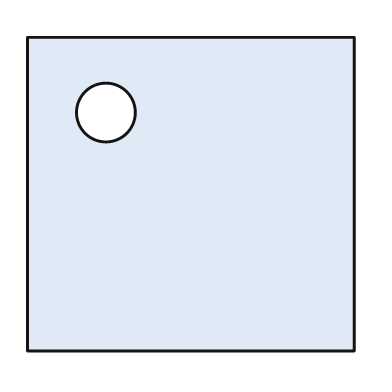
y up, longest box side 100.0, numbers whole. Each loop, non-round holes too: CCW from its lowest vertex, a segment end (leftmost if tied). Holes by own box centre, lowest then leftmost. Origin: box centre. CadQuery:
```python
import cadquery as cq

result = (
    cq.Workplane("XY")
    .moveTo(-50.0, -48.0)
    .lineTo(50.0, -48.0)
    .lineTo(50.0, 48.0)
    .lineTo(-50.0, 48.0)
    .close()
    .moveTo(-26.0, 25.0)
    .circle(9.0)
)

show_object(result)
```